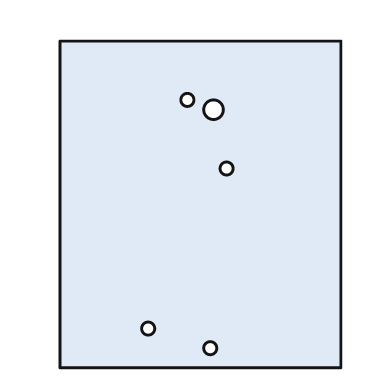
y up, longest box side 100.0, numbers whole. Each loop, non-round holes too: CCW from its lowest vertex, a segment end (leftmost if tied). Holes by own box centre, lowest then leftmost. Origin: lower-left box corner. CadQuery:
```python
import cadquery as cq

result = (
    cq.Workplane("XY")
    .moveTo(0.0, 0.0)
    .lineTo(86.0, 0.0)
    .lineTo(86.0, 100.0)
    .lineTo(0.0, 100.0)
    .close()
    .moveTo(46.0, 6.0)
    .circle(2.0)
    .moveTo(27.0, 12.0)
    .circle(2.0)
    .moveTo(51.0, 61.0)
    .circle(2.0)
    .moveTo(47.0, 79.0)
    .circle(3.0)
    .moveTo(39.0, 82.0)
    .circle(2.0)
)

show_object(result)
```